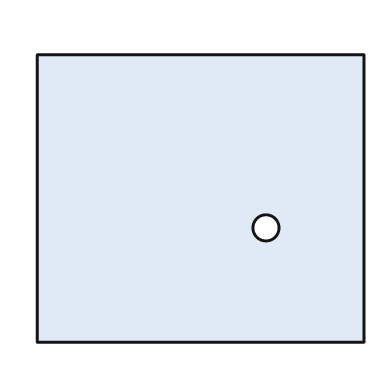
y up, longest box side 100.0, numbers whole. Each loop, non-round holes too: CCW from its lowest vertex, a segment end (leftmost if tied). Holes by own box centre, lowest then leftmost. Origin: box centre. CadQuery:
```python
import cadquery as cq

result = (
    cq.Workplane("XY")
    .moveTo(-50.0, -44.0)
    .lineTo(50.0, -44.0)
    .lineTo(50.0, 44.0)
    .lineTo(-50.0, 44.0)
    .close()
    .moveTo(20.0, -9.0)
    .circle(4.0)
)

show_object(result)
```